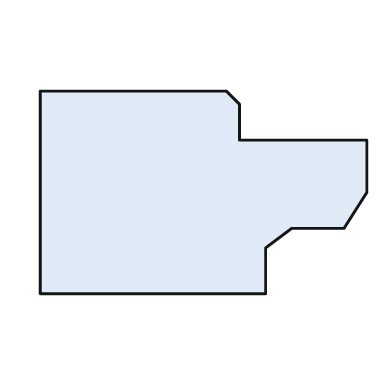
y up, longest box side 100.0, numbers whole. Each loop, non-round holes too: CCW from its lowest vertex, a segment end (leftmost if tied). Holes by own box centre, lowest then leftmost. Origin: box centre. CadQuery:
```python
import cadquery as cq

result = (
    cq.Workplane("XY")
    .moveTo(-50.0, -31.0)
    .lineTo(19.0, -31.0)
    .lineTo(19.0, -17.0)
    .lineTo(27.0, -11.0)
    .lineTo(43.0, -11.0)
    .lineTo(50.0, 0.0)
    .lineTo(50.0, 16.0)
    .lineTo(11.0, 16.0)
    .lineTo(11.0, 27.0)
    .lineTo(7.0, 31.0)
    .lineTo(-50.0, 31.0)
    .close()
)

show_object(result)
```